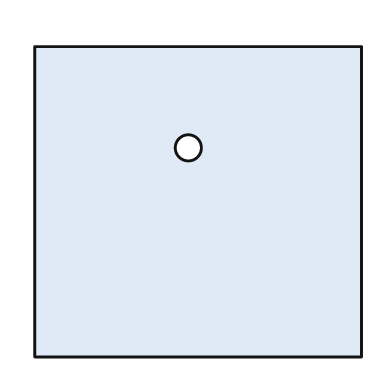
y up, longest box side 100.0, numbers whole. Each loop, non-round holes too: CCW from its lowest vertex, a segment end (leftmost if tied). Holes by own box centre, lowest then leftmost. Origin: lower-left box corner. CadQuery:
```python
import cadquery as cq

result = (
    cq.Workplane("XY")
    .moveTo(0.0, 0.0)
    .lineTo(100.0, 0.0)
    .lineTo(100.0, 95.0)
    .lineTo(0.0, 95.0)
    .close()
    .moveTo(47.0, 64.0)
    .circle(4.0)
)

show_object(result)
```